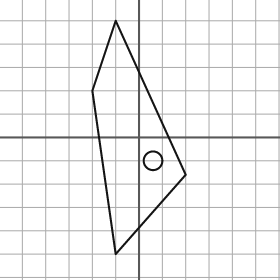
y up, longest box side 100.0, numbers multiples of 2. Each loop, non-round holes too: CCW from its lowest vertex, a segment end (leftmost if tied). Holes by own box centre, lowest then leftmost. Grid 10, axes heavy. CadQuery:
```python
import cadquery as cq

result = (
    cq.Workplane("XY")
    .moveTo(-10.0, -50.0)
    .lineTo(20.0, -16.0)
    .lineTo(-10.0, 50.0)
    .lineTo(-20.0, 20.0)
    .close()
    .moveTo(6.0, -10.0)
    .circle(4.0)
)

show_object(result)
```